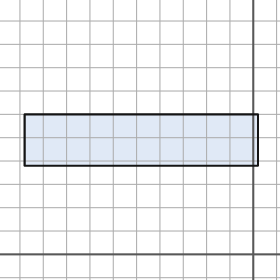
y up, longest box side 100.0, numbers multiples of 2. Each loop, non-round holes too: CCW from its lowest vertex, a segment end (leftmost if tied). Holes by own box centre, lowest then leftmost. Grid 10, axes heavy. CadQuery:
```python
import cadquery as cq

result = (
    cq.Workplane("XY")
    .moveTo(-98.0, 38.0)
    .lineTo(2.0, 38.0)
    .lineTo(2.0, 60.0)
    .lineTo(-98.0, 60.0)
    .close()
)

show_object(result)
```